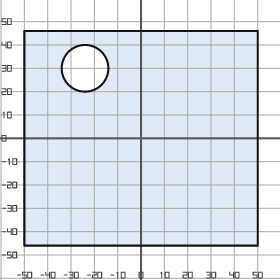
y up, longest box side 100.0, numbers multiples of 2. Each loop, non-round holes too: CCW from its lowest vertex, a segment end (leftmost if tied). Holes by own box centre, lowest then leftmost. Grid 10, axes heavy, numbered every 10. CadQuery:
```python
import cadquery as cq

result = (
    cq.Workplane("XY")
    .moveTo(-50.0, -46.0)
    .lineTo(50.0, -46.0)
    .lineTo(50.0, 46.0)
    .lineTo(-50.0, 46.0)
    .close()
    .moveTo(-24.0, 30.0)
    .circle(10.0)
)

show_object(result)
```